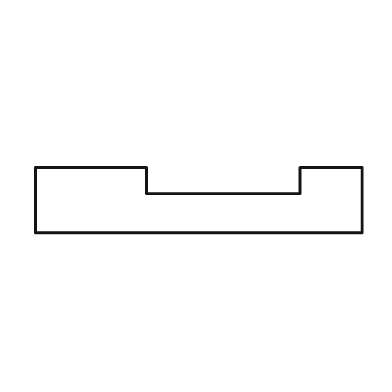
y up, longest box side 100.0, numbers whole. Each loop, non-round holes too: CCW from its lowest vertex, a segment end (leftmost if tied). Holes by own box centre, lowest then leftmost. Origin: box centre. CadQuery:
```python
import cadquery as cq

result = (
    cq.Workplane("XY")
    .moveTo(-50.0, -10.0)
    .lineTo(50.0, -10.0)
    .lineTo(50.0, 10.0)
    .lineTo(31.0, 10.0)
    .lineTo(31.0, 2.0)
    .lineTo(-16.0, 2.0)
    .lineTo(-16.0, 10.0)
    .lineTo(-50.0, 10.0)
    .close()
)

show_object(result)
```